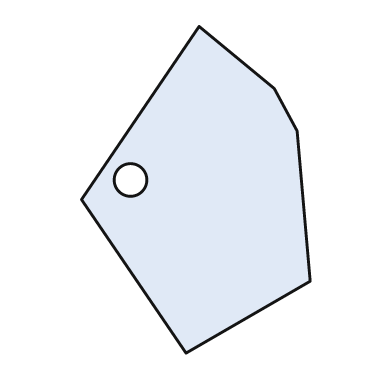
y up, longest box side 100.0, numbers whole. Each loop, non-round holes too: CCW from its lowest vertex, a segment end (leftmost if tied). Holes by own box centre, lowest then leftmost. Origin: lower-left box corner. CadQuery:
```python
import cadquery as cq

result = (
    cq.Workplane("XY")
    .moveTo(32.0, 0.0)
    .lineTo(70.0, 22.0)
    .lineTo(66.0, 68.0)
    .lineTo(59.0, 81.0)
    .lineTo(36.0, 100.0)
    .lineTo(0.0, 47.0)
    .close()
    .moveTo(15.0, 53.0)
    .circle(5.0)
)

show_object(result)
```